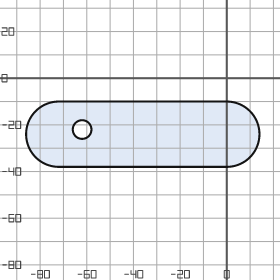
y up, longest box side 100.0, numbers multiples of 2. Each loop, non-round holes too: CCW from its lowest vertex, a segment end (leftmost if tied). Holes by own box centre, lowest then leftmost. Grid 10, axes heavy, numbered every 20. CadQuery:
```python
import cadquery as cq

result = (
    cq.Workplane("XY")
    .moveTo(-72.0, -38.0)
    .lineTo(0.0, -38.0)
    .threePointArc((14.0, -24.0), (0.0, -10.0))
    .lineTo(-72.0, -10.0)
    .threePointArc((-86.0, -24.0), (-72.0, -38.0))
    .close()
    .moveTo(-62.0, -22.0)
    .circle(4.0)
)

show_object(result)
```